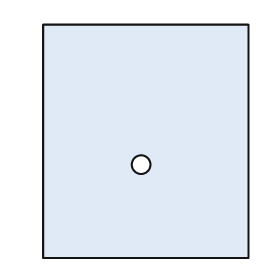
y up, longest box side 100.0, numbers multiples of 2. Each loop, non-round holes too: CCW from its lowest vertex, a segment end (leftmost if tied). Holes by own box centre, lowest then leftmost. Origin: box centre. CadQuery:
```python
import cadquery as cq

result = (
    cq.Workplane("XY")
    .moveTo(-44.0, -50.0)
    .lineTo(44.0, -50.0)
    .lineTo(44.0, 50.0)
    .lineTo(-44.0, 50.0)
    .close()
    .moveTo(-2.0, -10.0)
    .circle(4.0)
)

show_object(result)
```